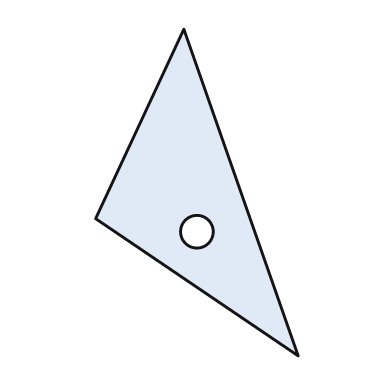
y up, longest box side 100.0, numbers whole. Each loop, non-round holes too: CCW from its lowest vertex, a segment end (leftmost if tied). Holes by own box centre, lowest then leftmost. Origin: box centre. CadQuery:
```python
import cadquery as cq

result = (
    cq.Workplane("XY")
    .moveTo(31.0, -50.0)
    .lineTo(-4.0, 50.0)
    .lineTo(-31.0, -8.0)
    .close()
    .moveTo(0.0, -12.0)
    .circle(5.0)
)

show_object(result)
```